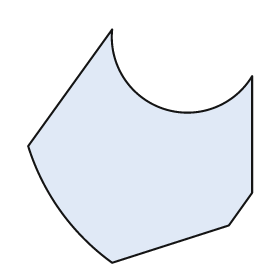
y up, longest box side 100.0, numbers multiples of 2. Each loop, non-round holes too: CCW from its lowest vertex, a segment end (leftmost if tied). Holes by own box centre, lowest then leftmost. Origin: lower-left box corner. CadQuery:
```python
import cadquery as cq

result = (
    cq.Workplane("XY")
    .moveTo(36.0, 0.0)
    .lineTo(86.0, 16.0)
    .lineTo(96.0, 30.0)
    .lineTo(96.0, 80.0)
    .threePointArc((58.0, 66.0), (36.0, 100.0))
    .lineTo(0.0, 50.0)
    .threePointArc((14.0, 22.0), (36.0, 0.0))
    .close()
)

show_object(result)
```